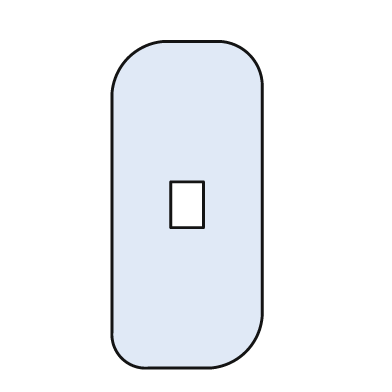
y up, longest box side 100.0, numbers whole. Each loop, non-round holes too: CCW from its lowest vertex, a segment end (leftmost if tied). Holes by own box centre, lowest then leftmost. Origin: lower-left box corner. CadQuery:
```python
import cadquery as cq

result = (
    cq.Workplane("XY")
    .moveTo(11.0, 0.0)
    .lineTo(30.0, 0.0)
    .threePointArc((41.0, 5.0), (46.0, 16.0))
    .lineTo(46.0, 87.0)
    .threePointArc((42.0, 96.0), (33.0, 100.0))
    .lineTo(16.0, 100.0)
    .threePointArc((5.0, 95.0), (0.0, 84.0))
    .lineTo(0.0, 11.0)
    .threePointArc((3.0, 3.0), (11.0, 0.0))
    .close()
    .moveTo(18.0, 43.0)
    .lineTo(28.0, 43.0)
    .lineTo(28.0, 57.0)
    .lineTo(18.0, 57.0)
    .close()
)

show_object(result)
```